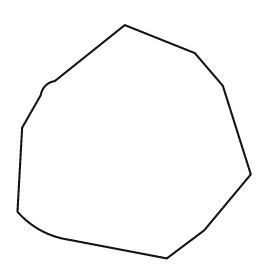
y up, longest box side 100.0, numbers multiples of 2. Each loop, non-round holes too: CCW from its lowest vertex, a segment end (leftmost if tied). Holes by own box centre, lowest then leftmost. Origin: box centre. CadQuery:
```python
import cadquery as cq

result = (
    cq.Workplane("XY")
    .moveTo(14.0, -50.0)
    .lineTo(30.0, -38.0)
    .lineTo(50.0, -14.0)
    .lineTo(38.0, 24.0)
    .lineTo(26.0, 38.0)
    .lineTo(-4.0, 50.0)
    .lineTo(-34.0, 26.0)
    .threePointArc((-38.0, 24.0), (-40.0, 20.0))
    .lineTo(-48.0, 6.0)
    .lineTo(-50.0, -30.0)
    .threePointArc((-40.0, -38.0), (-28.0, -42.0))
    .close()
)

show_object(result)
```